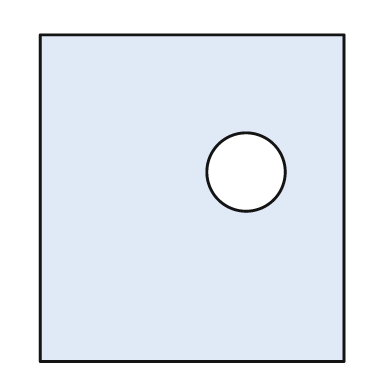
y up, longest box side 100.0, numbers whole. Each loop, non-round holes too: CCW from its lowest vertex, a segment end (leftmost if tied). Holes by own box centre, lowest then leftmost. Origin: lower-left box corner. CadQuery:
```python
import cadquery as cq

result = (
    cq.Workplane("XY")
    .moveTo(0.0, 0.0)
    .lineTo(93.0, 0.0)
    .lineTo(93.0, 100.0)
    .lineTo(0.0, 100.0)
    .close()
    .moveTo(63.0, 58.0)
    .circle(12.0)
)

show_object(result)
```